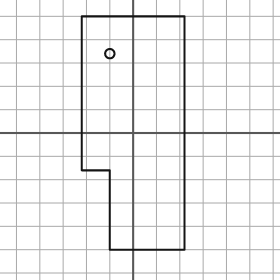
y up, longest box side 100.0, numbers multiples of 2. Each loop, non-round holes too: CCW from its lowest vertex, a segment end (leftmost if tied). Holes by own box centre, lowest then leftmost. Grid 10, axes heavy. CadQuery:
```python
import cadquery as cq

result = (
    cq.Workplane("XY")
    .moveTo(-10.0, -50.0)
    .lineTo(22.0, -50.0)
    .lineTo(22.0, 50.0)
    .lineTo(-22.0, 50.0)
    .lineTo(-22.0, -16.0)
    .lineTo(-10.0, -16.0)
    .close()
    .moveTo(-10.0, 34.0)
    .circle(2.0)
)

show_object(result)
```